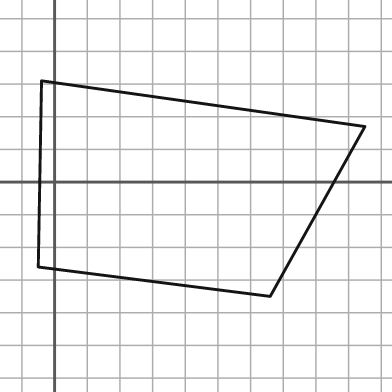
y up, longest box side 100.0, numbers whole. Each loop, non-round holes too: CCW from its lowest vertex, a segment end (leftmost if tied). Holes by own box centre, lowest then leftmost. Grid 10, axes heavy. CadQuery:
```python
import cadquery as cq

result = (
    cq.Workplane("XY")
    .moveTo(66.0, -35.0)
    .lineTo(95.0, 17.0)
    .lineTo(-4.0, 31.0)
    .lineTo(-5.0, -26.0)
    .close()
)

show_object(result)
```